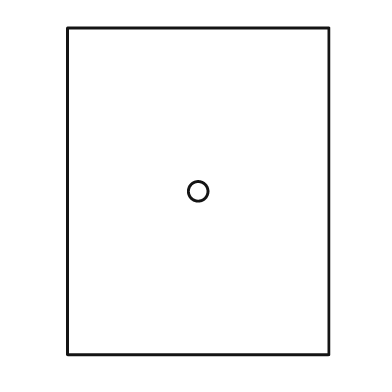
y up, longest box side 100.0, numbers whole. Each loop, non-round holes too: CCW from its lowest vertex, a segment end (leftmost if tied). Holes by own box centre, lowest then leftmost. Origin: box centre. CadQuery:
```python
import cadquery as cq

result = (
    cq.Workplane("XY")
    .moveTo(-40.0, -50.0)
    .lineTo(40.0, -50.0)
    .lineTo(40.0, 50.0)
    .lineTo(-40.0, 50.0)
    .close()
    .moveTo(0.0, 0.0)
    .circle(3.0)
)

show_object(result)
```